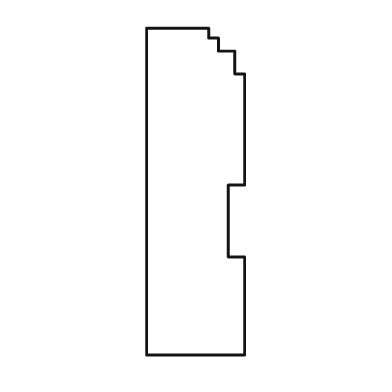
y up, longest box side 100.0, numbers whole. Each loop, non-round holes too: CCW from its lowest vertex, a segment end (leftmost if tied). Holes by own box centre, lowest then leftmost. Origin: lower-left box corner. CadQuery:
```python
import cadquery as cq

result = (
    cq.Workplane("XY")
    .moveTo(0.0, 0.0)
    .lineTo(30.0, 0.0)
    .lineTo(30.0, 30.0)
    .lineTo(25.0, 30.0)
    .lineTo(25.0, 52.0)
    .lineTo(30.0, 52.0)
    .lineTo(30.0, 86.0)
    .lineTo(27.0, 86.0)
    .lineTo(27.0, 93.0)
    .lineTo(22.0, 93.0)
    .lineTo(22.0, 97.0)
    .lineTo(19.0, 97.0)
    .lineTo(19.0, 100.0)
    .lineTo(0.0, 100.0)
    .close()
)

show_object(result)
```